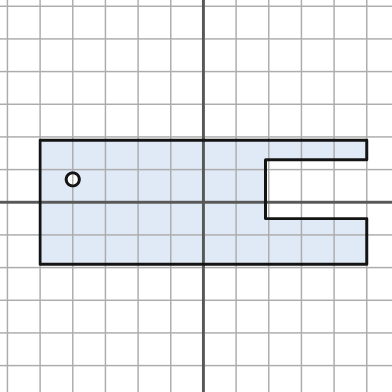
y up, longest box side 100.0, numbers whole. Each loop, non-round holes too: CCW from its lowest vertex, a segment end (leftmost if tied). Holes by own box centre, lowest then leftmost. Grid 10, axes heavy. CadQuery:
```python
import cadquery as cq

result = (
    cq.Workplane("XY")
    .moveTo(-50.0, -19.0)
    .lineTo(50.0, -19.0)
    .lineTo(50.0, -5.0)
    .lineTo(19.0, -5.0)
    .lineTo(19.0, 13.0)
    .lineTo(50.0, 13.0)
    .lineTo(50.0, 19.0)
    .lineTo(-50.0, 19.0)
    .close()
    .moveTo(-40.0, 7.0)
    .circle(2.0)
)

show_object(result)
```